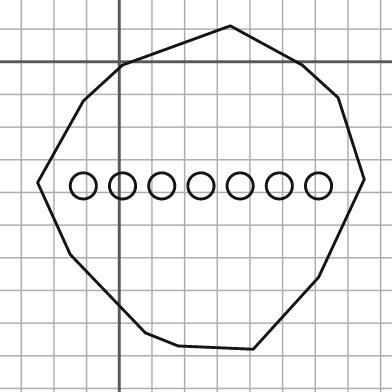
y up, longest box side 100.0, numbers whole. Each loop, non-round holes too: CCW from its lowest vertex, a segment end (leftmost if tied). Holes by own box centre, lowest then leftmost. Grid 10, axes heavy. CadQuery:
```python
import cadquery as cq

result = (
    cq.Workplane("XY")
    .moveTo(41.0, -88.0)
    .lineTo(61.0, -66.0)
    .lineTo(75.0, -36.0)
    .lineTo(67.0, -11.0)
    .lineTo(56.0, -1.0)
    .lineTo(34.0, 11.0)
    .lineTo(1.0, -1.0)
    .lineTo(-11.0, -12.0)
    .lineTo(-25.0, -37.0)
    .lineTo(-15.0, -59.0)
    .lineTo(8.0, -83.0)
    .lineTo(18.0, -87.0)
    .close()
    .moveTo(-11.0, -38.0)
    .circle(4.0)
    .moveTo(1.0, -38.0)
    .circle(4.0)
    .moveTo(13.0, -38.0)
    .circle(4.0)
    .moveTo(25.0, -38.0)
    .circle(4.0)
    .moveTo(37.0, -38.0)
    .circle(4.0)
    .moveTo(49.0, -38.0)
    .circle(4.0)
    .moveTo(61.0, -38.0)
    .circle(4.0)
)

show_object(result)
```